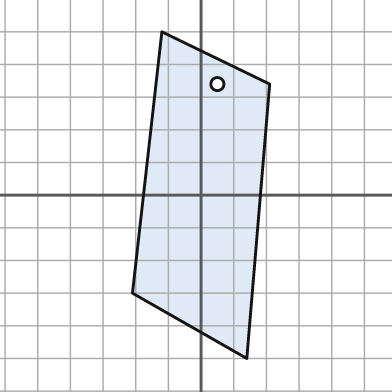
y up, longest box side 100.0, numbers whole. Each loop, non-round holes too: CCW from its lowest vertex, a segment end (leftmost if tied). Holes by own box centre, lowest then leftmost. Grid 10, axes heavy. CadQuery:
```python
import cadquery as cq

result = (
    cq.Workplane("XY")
    .moveTo(14.0, -50.0)
    .lineTo(21.0, 34.0)
    .lineTo(-12.0, 50.0)
    .lineTo(-21.0, -30.0)
    .close()
    .moveTo(5.0, 34.0)
    .circle(2.0)
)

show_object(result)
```